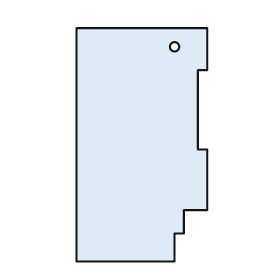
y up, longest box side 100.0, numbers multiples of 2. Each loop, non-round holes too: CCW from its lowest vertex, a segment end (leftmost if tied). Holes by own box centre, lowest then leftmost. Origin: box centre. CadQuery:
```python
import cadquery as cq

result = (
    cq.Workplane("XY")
    .moveTo(-28.0, -50.0)
    .lineTo(14.0, -50.0)
    .lineTo(14.0, -38.0)
    .lineTo(18.0, -38.0)
    .lineTo(18.0, -28.0)
    .lineTo(28.0, -28.0)
    .lineTo(28.0, -2.0)
    .lineTo(24.0, -2.0)
    .lineTo(24.0, 32.0)
    .lineTo(28.0, 32.0)
    .lineTo(28.0, 50.0)
    .lineTo(-28.0, 50.0)
    .close()
    .moveTo(14.0, 42.0)
    .circle(2.0)
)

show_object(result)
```